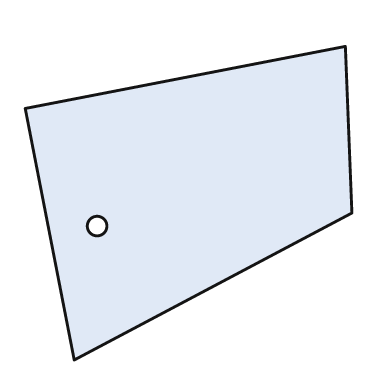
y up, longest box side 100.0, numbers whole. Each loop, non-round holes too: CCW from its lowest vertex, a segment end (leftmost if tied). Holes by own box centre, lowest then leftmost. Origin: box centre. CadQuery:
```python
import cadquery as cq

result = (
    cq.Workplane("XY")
    .moveTo(-35.0, -48.0)
    .lineTo(50.0, -3.0)
    .lineTo(48.0, 48.0)
    .lineTo(-50.0, 29.0)
    .close()
    .moveTo(-28.0, -7.0)
    .circle(3.0)
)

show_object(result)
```